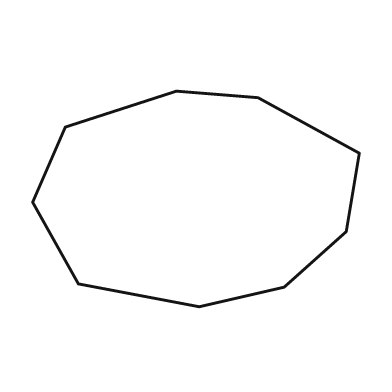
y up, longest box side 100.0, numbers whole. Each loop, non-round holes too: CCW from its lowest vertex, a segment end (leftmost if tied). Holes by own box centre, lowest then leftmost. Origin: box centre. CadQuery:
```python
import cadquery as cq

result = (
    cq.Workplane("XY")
    .moveTo(1.0, -33.0)
    .lineTo(27.0, -27.0)
    .lineTo(46.0, -10.0)
    .lineTo(50.0, 14.0)
    .lineTo(19.0, 31.0)
    .lineTo(-6.0, 33.0)
    .lineTo(-40.0, 22.0)
    .lineTo(-50.0, -1.0)
    .lineTo(-36.0, -26.0)
    .close()
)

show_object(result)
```